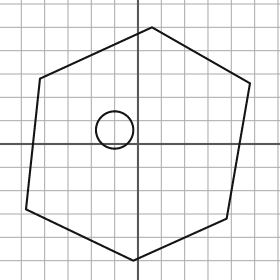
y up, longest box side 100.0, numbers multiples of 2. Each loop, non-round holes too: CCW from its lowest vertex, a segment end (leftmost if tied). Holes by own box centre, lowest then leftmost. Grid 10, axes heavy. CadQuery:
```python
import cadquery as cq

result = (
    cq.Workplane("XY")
    .moveTo(-2.0, -50.0)
    .lineTo(38.0, -32.0)
    .lineTo(48.0, 26.0)
    .lineTo(6.0, 50.0)
    .lineTo(-42.0, 28.0)
    .lineTo(-48.0, -28.0)
    .close()
    .moveTo(-10.0, 6.0)
    .circle(8.0)
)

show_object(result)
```